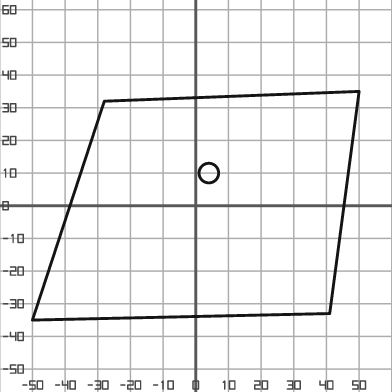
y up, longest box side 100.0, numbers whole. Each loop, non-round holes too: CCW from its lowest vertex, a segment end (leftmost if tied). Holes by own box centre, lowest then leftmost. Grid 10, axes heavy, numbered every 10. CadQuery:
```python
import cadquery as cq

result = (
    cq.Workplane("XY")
    .moveTo(-50.0, -35.0)
    .lineTo(41.0, -33.0)
    .lineTo(50.0, 35.0)
    .lineTo(-28.0, 32.0)
    .close()
    .moveTo(4.0, 10.0)
    .circle(3.0)
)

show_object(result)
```